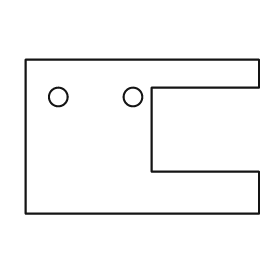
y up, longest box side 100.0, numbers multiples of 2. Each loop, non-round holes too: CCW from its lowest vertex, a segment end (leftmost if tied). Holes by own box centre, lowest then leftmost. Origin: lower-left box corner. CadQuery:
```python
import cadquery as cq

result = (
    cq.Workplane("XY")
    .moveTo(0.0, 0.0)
    .lineTo(100.0, 0.0)
    .lineTo(100.0, 18.0)
    .lineTo(54.0, 18.0)
    .lineTo(54.0, 54.0)
    .lineTo(100.0, 54.0)
    .lineTo(100.0, 66.0)
    .lineTo(0.0, 66.0)
    .close()
    .moveTo(14.0, 50.0)
    .circle(4.0)
    .moveTo(46.0, 50.0)
    .circle(4.0)
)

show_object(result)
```